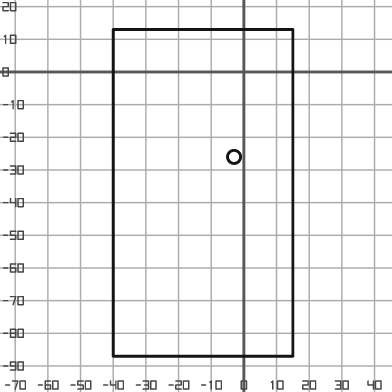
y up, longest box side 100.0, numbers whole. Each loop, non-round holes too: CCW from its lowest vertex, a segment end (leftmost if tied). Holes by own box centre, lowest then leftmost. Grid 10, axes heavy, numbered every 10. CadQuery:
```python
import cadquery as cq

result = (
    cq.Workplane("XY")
    .moveTo(-40.0, -87.0)
    .lineTo(15.0, -87.0)
    .lineTo(15.0, 13.0)
    .lineTo(-40.0, 13.0)
    .close()
    .moveTo(-3.0, -26.0)
    .circle(2.0)
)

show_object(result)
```